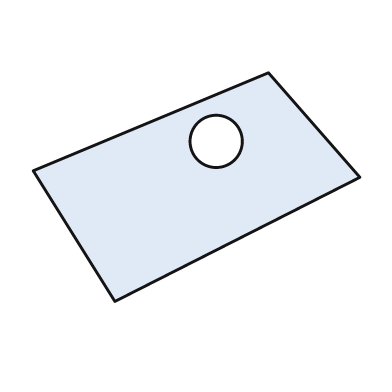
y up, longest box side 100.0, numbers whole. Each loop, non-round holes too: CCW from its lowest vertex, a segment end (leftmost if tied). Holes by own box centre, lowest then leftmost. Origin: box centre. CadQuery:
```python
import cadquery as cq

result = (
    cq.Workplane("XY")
    .moveTo(-25.0, -35.0)
    .lineTo(50.0, 3.0)
    .lineTo(22.0, 35.0)
    .lineTo(-50.0, 5.0)
    .close()
    .moveTo(6.0, 14.0)
    .circle(8.0)
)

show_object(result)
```